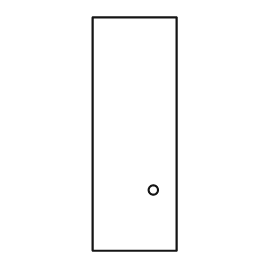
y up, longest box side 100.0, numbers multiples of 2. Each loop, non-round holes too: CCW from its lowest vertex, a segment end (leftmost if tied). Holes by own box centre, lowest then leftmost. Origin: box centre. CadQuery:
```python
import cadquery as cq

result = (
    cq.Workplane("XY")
    .moveTo(-18.0, -50.0)
    .lineTo(18.0, -50.0)
    .lineTo(18.0, 50.0)
    .lineTo(-18.0, 50.0)
    .close()
    .moveTo(8.0, -24.0)
    .circle(2.0)
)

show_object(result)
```